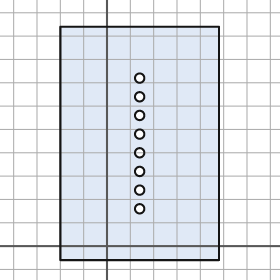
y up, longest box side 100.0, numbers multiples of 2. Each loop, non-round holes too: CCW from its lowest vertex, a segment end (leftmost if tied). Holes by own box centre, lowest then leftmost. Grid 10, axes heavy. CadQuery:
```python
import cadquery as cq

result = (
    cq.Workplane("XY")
    .moveTo(-20.0, -6.0)
    .lineTo(48.0, -6.0)
    .lineTo(48.0, 94.0)
    .lineTo(-20.0, 94.0)
    .close()
    .moveTo(14.0, 16.0)
    .circle(2.0)
    .moveTo(14.0, 24.0)
    .circle(2.0)
    .moveTo(14.0, 32.0)
    .circle(2.0)
    .moveTo(14.0, 40.0)
    .circle(2.0)
    .moveTo(14.0, 48.0)
    .circle(2.0)
    .moveTo(14.0, 56.0)
    .circle(2.0)
    .moveTo(14.0, 64.0)
    .circle(2.0)
    .moveTo(14.0, 72.0)
    .circle(2.0)
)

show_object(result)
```